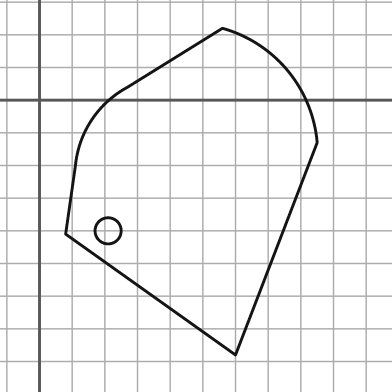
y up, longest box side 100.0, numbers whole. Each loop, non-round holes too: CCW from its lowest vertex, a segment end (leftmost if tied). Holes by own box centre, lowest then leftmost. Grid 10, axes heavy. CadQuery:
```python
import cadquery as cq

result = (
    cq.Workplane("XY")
    .moveTo(60.0, -78.0)
    .lineTo(85.0, -13.0)
    .threePointArc((76.0, 9.0), (56.0, 22.0))
    .lineTo(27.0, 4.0)
    .threePointArc((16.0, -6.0), (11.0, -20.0))
    .lineTo(8.0, -41.0)
    .close()
    .moveTo(21.0, -40.0)
    .circle(4.0)
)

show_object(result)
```